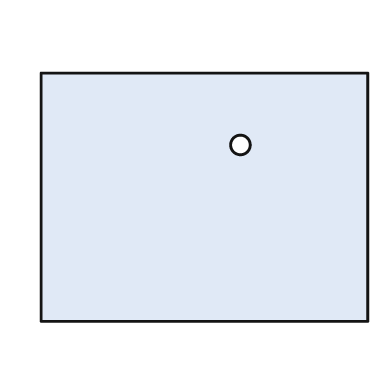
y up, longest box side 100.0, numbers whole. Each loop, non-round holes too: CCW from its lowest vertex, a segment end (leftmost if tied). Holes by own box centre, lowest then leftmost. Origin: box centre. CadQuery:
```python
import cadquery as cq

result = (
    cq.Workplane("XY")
    .moveTo(-50.0, -38.0)
    .lineTo(50.0, -38.0)
    .lineTo(50.0, 38.0)
    .lineTo(-50.0, 38.0)
    .close()
    .moveTo(11.0, 16.0)
    .circle(3.0)
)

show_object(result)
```